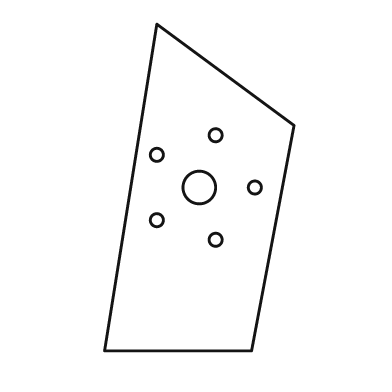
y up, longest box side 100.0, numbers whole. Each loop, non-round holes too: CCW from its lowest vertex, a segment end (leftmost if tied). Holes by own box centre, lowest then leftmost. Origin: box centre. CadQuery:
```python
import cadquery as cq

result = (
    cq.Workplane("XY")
    .moveTo(-29.0, -50.0)
    .lineTo(16.0, -50.0)
    .lineTo(29.0, 19.0)
    .lineTo(-13.0, 50.0)
    .close()
    .moveTo(5.0, -16.0)
    .circle(2.0)
    .moveTo(-13.0, -10.0)
    .circle(2.0)
    .moveTo(0.0, 0.0)
    .circle(5.0)
    .moveTo(17.0, 0.0)
    .circle(2.0)
    .moveTo(-13.0, 10.0)
    .circle(2.0)
    .moveTo(5.0, 16.0)
    .circle(2.0)
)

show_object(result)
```